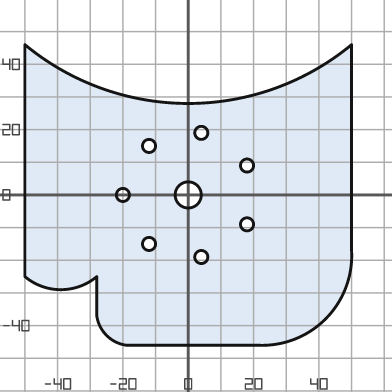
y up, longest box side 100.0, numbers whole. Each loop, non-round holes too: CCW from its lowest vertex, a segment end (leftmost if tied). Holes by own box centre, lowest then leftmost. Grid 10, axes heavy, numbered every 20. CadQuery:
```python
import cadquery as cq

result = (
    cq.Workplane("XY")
    .moveTo(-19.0, -46.0)
    .lineTo(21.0, -46.0)
    .threePointArc((42.0, -38.0), (50.0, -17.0))
    .lineTo(50.0, 46.0)
    .threePointArc((0.0, 28.0), (-50.0, 46.0))
    .lineTo(-50.0, -25.0)
    .threePointArc((-39.0, -29.0), (-28.0, -25.0))
    .lineTo(-28.0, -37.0)
    .threePointArc((-25.0, -43.0), (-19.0, -46.0))
    .close()
    .moveTo(4.0, -19.0)
    .circle(2.0)
    .moveTo(-12.0, -15.0)
    .circle(2.0)
    .moveTo(18.0, -9.0)
    .circle(2.0)
    .moveTo(-20.0, 0.0)
    .circle(2.0)
    .moveTo(0.0, 0.0)
    .circle(4.0)
    .moveTo(18.0, 9.0)
    .circle(2.0)
    .moveTo(-12.0, 15.0)
    .circle(2.0)
    .moveTo(4.0, 19.0)
    .circle(2.0)
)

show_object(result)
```